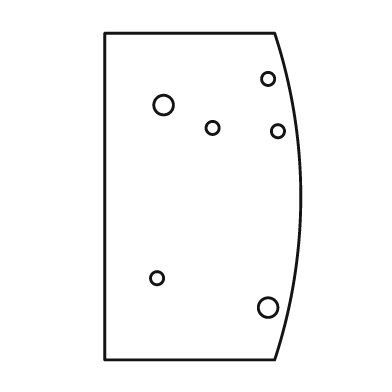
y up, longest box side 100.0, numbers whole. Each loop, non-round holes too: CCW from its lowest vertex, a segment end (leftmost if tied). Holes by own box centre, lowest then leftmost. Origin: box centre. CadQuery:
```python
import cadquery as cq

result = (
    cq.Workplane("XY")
    .moveTo(-30.0, -50.0)
    .lineTo(22.0, -50.0)
    .threePointArc((30.0, 0.0), (22.0, 50.0))
    .lineTo(-30.0, 50.0)
    .close()
    .moveTo(20.0, -34.0)
    .circle(3.0)
    .moveTo(-14.0, -25.0)
    .circle(2.0)
    .moveTo(23.0, 20.0)
    .circle(2.0)
    .moveTo(3.0, 21.0)
    .circle(2.0)
    .moveTo(-12.0, 28.0)
    .circle(3.0)
    .moveTo(20.0, 36.0)
    .circle(2.0)
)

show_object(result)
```